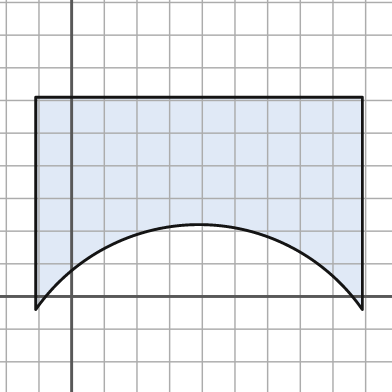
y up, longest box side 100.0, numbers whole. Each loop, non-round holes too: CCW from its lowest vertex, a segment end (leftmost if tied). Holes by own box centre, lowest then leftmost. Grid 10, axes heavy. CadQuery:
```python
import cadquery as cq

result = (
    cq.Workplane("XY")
    .moveTo(-11.0, -4.0)
    .threePointArc((39.0, 22.0), (89.0, -4.0))
    .lineTo(89.0, 61.0)
    .lineTo(-11.0, 61.0)
    .close()
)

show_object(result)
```